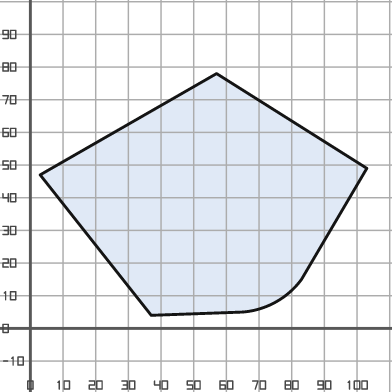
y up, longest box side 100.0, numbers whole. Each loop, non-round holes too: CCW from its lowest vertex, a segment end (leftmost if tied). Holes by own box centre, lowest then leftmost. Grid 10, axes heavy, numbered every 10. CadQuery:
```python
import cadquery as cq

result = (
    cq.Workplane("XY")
    .moveTo(37.0, 4.0)
    .lineTo(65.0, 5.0)
    .threePointArc((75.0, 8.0), (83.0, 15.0))
    .lineTo(103.0, 49.0)
    .lineTo(57.0, 78.0)
    .lineTo(3.0, 47.0)
    .close()
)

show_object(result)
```